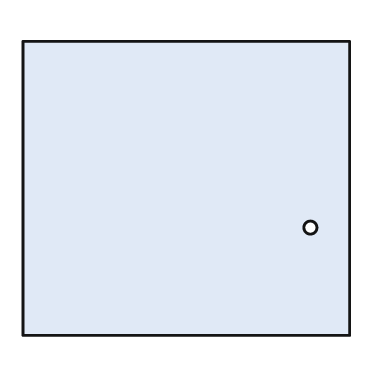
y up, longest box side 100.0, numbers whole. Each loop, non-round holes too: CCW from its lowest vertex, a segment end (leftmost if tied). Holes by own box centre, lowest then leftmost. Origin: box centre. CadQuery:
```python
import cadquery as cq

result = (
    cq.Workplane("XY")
    .moveTo(-50.0, -45.0)
    .lineTo(50.0, -45.0)
    .lineTo(50.0, 45.0)
    .lineTo(-50.0, 45.0)
    .close()
    .moveTo(38.0, -12.0)
    .circle(2.0)
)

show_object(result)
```